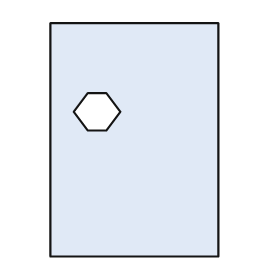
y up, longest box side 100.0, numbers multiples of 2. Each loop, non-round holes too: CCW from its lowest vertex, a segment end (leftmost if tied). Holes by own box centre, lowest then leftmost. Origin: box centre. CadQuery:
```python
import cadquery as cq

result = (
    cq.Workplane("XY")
    .moveTo(-36.0, -50.0)
    .lineTo(36.0, -50.0)
    .lineTo(36.0, 50.0)
    .lineTo(-36.0, 50.0)
    .close()
    .moveTo(-20.0, 4.0)
    .lineTo(-12.0, 4.0)
    .lineTo(-6.0, 12.0)
    .lineTo(-12.0, 20.0)
    .lineTo(-20.0, 20.0)
    .lineTo(-26.0, 12.0)
    .close()
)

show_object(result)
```